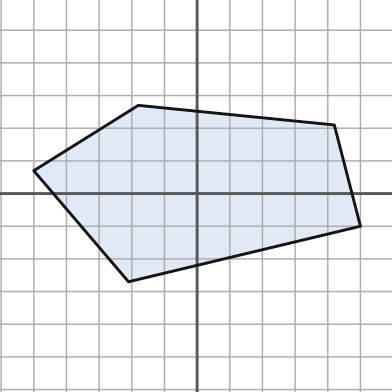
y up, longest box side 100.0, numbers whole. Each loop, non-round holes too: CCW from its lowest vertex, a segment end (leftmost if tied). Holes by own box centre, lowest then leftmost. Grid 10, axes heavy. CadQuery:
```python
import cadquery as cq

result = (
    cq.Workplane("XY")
    .moveTo(-21.0, -27.0)
    .lineTo(50.0, -10.0)
    .lineTo(42.0, 21.0)
    .lineTo(-18.0, 27.0)
    .lineTo(-50.0, 7.0)
    .close()
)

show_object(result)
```